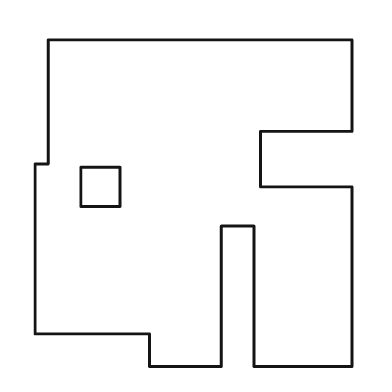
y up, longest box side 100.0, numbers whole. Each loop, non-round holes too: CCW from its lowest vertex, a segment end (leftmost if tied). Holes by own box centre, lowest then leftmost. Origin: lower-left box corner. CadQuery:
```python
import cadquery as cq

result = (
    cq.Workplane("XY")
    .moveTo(35.0, 0.0)
    .lineTo(57.0, 0.0)
    .lineTo(57.0, 43.0)
    .lineTo(67.0, 43.0)
    .lineTo(67.0, 0.0)
    .lineTo(97.0, 0.0)
    .lineTo(97.0, 55.0)
    .lineTo(69.0, 55.0)
    .lineTo(69.0, 72.0)
    .lineTo(97.0, 72.0)
    .lineTo(97.0, 100.0)
    .lineTo(4.0, 100.0)
    .lineTo(4.0, 62.0)
    .lineTo(0.0, 62.0)
    .lineTo(0.0, 10.0)
    .lineTo(35.0, 10.0)
    .close()
    .moveTo(14.0, 49.0)
    .lineTo(26.0, 49.0)
    .lineTo(26.0, 61.0)
    .lineTo(14.0, 61.0)
    .close()
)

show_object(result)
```